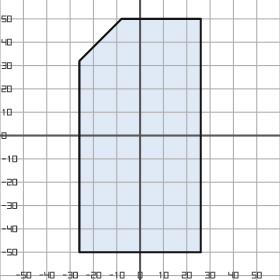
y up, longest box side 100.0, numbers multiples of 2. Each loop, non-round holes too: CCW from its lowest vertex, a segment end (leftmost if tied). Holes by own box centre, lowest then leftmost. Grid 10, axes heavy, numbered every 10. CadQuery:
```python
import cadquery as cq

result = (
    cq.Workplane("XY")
    .moveTo(-26.0, -50.0)
    .lineTo(26.0, -50.0)
    .lineTo(26.0, 50.0)
    .lineTo(-8.0, 50.0)
    .lineTo(-26.0, 32.0)
    .close()
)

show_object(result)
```